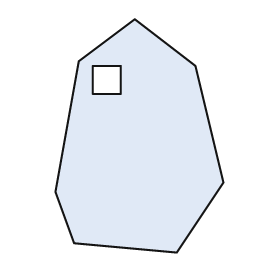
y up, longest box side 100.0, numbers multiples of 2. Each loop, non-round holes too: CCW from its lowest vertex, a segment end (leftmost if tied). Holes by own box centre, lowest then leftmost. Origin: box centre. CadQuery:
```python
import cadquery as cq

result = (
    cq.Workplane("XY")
    .moveTo(16.0, -50.0)
    .lineTo(36.0, -20.0)
    .lineTo(24.0, 30.0)
    .lineTo(-2.0, 50.0)
    .lineTo(-26.0, 32.0)
    .lineTo(-36.0, -24.0)
    .lineTo(-28.0, -46.0)
    .close()
    .moveTo(-20.0, 18.0)
    .lineTo(-8.0, 18.0)
    .lineTo(-8.0, 30.0)
    .lineTo(-20.0, 30.0)
    .close()
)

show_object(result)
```